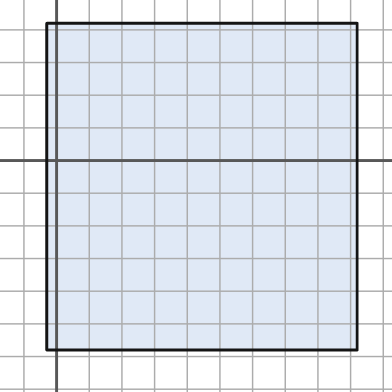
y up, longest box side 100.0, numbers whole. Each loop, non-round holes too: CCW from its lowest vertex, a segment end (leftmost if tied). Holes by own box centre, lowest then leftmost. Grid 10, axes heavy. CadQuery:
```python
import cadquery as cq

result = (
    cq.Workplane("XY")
    .moveTo(-3.0, -58.0)
    .lineTo(92.0, -58.0)
    .lineTo(92.0, 42.0)
    .lineTo(-3.0, 42.0)
    .close()
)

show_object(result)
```